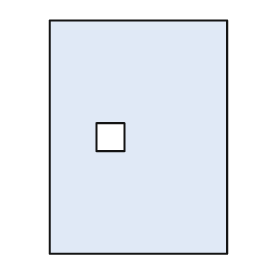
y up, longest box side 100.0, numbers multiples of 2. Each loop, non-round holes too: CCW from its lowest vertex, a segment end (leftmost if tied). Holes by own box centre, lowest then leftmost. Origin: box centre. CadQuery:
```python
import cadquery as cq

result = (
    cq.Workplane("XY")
    .moveTo(-38.0, -50.0)
    .lineTo(38.0, -50.0)
    .lineTo(38.0, 50.0)
    .lineTo(-38.0, 50.0)
    .close()
    .moveTo(-18.0, -6.0)
    .lineTo(-6.0, -6.0)
    .lineTo(-6.0, 6.0)
    .lineTo(-18.0, 6.0)
    .close()
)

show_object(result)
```